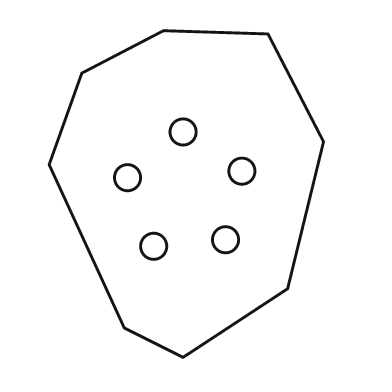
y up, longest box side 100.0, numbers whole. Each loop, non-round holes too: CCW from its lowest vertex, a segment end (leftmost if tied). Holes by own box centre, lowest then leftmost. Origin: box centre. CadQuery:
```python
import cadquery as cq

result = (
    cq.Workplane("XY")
    .moveTo(-1.0, -50.0)
    .lineTo(31.0, -29.0)
    .lineTo(42.0, 16.0)
    .lineTo(25.0, 49.0)
    .lineTo(-7.0, 50.0)
    .lineTo(-32.0, 37.0)
    .lineTo(-42.0, 9.0)
    .lineTo(-19.0, -41.0)
    .close()
    .moveTo(-10.0, -16.0)
    .circle(4.0)
    .moveTo(12.0, -14.0)
    .circle(4.0)
    .moveTo(-18.0, 5.0)
    .circle(4.0)
    .moveTo(17.0, 7.0)
    .circle(4.0)
    .moveTo(-1.0, 19.0)
    .circle(4.0)
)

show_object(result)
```